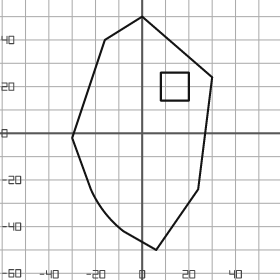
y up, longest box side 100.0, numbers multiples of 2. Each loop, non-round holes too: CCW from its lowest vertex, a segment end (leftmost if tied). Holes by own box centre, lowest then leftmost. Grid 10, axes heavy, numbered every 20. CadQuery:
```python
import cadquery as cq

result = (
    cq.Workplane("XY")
    .moveTo(6.0, -50.0)
    .lineTo(24.0, -24.0)
    .lineTo(30.0, 24.0)
    .lineTo(0.0, 50.0)
    .lineTo(-16.0, 40.0)
    .lineTo(-30.0, -2.0)
    .lineTo(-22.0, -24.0)
    .threePointArc((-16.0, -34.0), (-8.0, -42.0))
    .close()
    .moveTo(8.0, 14.0)
    .lineTo(20.0, 14.0)
    .lineTo(20.0, 26.0)
    .lineTo(8.0, 26.0)
    .close()
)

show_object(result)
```